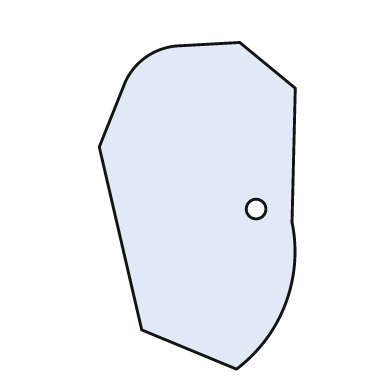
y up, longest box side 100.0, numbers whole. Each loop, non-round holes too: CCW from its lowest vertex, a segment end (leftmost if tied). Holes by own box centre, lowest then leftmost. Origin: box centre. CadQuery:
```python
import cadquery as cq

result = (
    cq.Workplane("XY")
    .moveTo(12.0, -50.0)
    .threePointArc((27.0, -30.0), (29.0, -5.0))
    .lineTo(30.0, 36.0)
    .lineTo(13.0, 50.0)
    .lineTo(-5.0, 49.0)
    .threePointArc((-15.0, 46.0), (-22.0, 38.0))
    .lineTo(-30.0, 18.0)
    .lineTo(-17.0, -38.0)
    .close()
    .moveTo(18.0, -1.0)
    .circle(3.0)
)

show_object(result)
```